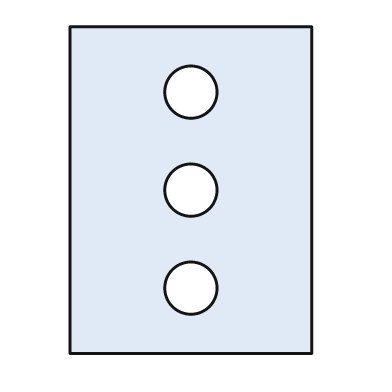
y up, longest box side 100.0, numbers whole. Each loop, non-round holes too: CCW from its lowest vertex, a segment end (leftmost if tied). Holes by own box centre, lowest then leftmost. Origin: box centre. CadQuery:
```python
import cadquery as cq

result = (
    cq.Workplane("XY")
    .moveTo(-37.0, -50.0)
    .lineTo(37.0, -50.0)
    .lineTo(37.0, 50.0)
    .lineTo(-37.0, 50.0)
    .close()
    .moveTo(0.0, -30.0)
    .circle(8.0)
    .moveTo(0.0, 0.0)
    .circle(8.0)
    .moveTo(0.0, 30.0)
    .circle(8.0)
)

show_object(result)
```